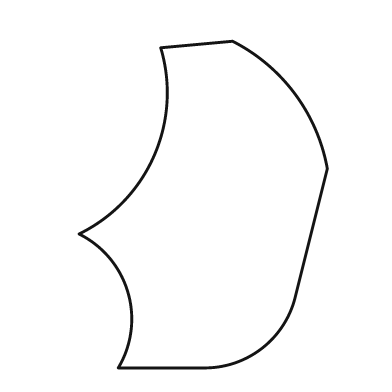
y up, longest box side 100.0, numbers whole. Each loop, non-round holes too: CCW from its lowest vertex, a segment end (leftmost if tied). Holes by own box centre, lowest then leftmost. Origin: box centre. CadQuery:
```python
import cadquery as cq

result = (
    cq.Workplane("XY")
    .moveTo(-26.0, -50.0)
    .lineTo(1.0, -50.0)
    .threePointArc((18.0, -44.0), (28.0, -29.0))
    .lineTo(38.0, 11.0)
    .threePointArc((28.0, 34.0), (9.0, 50.0))
    .lineTo(-13.0, 48.0)
    .threePointArc((-15.0, 15.0), (-38.0, -9.0))
    .threePointArc((-23.0, -27.0), (-26.0, -50.0))
    .close()
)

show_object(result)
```